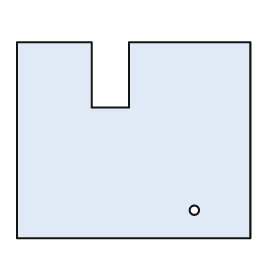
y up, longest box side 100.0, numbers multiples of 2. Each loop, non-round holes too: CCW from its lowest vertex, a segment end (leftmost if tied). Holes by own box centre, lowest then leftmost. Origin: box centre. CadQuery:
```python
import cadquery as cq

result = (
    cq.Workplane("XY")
    .moveTo(-50.0, -42.0)
    .lineTo(50.0, -42.0)
    .lineTo(50.0, 42.0)
    .lineTo(-2.0, 42.0)
    .lineTo(-2.0, 14.0)
    .lineTo(-18.0, 14.0)
    .lineTo(-18.0, 42.0)
    .lineTo(-50.0, 42.0)
    .close()
    .moveTo(26.0, -30.0)
    .circle(2.0)
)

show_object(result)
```